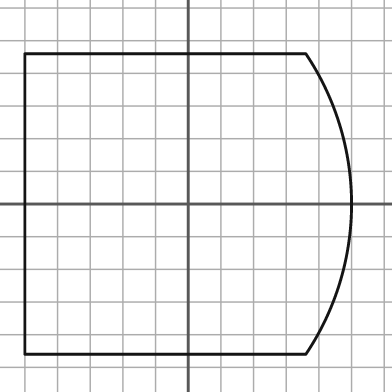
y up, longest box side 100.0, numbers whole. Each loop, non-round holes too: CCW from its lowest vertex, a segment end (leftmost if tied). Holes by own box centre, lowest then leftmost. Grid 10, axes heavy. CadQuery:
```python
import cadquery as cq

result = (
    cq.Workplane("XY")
    .moveTo(-50.0, -46.0)
    .lineTo(36.0, -46.0)
    .threePointArc((50.0, 0.0), (36.0, 46.0))
    .lineTo(-50.0, 46.0)
    .close()
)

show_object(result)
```